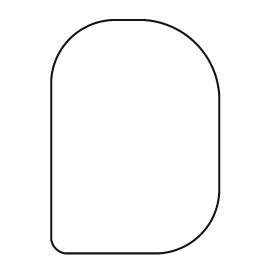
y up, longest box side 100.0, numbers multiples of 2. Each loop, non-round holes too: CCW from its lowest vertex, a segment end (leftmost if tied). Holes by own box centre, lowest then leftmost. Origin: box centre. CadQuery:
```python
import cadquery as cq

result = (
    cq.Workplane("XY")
    .moveTo(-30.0, -50.0)
    .lineTo(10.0, -50.0)
    .threePointArc((28.0, -42.0), (36.0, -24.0))
    .lineTo(36.0, 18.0)
    .threePointArc((26.0, 40.0), (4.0, 50.0))
    .lineTo(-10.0, 50.0)
    .threePointArc((-28.0, 42.0), (-36.0, 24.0))
    .lineTo(-36.0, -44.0)
    .threePointArc((-34.0, -48.0), (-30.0, -50.0))
    .close()
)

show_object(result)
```